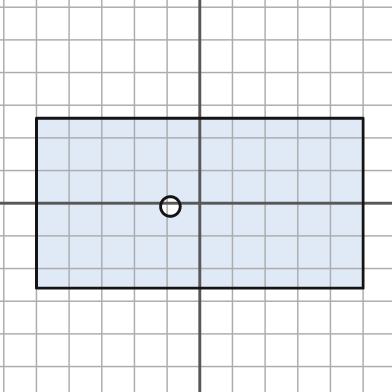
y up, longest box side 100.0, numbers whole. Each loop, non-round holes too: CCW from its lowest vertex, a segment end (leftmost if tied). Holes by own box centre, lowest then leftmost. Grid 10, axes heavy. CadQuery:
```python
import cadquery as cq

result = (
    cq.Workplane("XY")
    .moveTo(-50.0, -26.0)
    .lineTo(50.0, -26.0)
    .lineTo(50.0, 26.0)
    .lineTo(-50.0, 26.0)
    .close()
    .moveTo(-9.0, -1.0)
    .circle(3.0)
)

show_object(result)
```